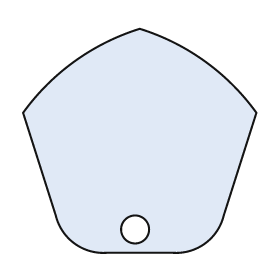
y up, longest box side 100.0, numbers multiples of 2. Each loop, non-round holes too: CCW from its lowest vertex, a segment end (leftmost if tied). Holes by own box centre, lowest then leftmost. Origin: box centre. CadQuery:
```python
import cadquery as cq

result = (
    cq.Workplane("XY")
    .moveTo(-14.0, -48.0)
    .lineTo(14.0, -48.0)
    .threePointArc((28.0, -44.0), (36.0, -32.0))
    .lineTo(50.0, 12.0)
    .threePointArc((28.0, 34.0), (0.0, 48.0))
    .threePointArc((-28.0, 34.0), (-50.0, 12.0))
    .lineTo(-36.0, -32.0)
    .threePointArc((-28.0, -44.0), (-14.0, -48.0))
    .close()
    .moveTo(-2.0, -38.0)
    .circle(6.0)
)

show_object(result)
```